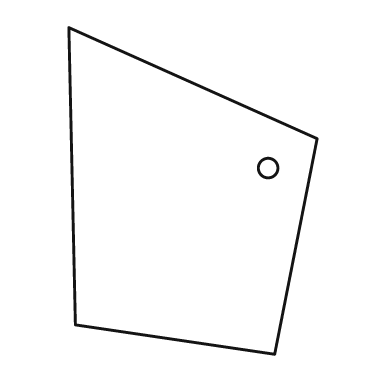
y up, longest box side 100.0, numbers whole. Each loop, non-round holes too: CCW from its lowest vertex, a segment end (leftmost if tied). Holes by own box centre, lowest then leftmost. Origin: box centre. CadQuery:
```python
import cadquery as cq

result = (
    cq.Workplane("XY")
    .moveTo(25.0, -50.0)
    .lineTo(38.0, 16.0)
    .lineTo(-38.0, 50.0)
    .lineTo(-36.0, -41.0)
    .close()
    .moveTo(23.0, 7.0)
    .circle(3.0)
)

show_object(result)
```